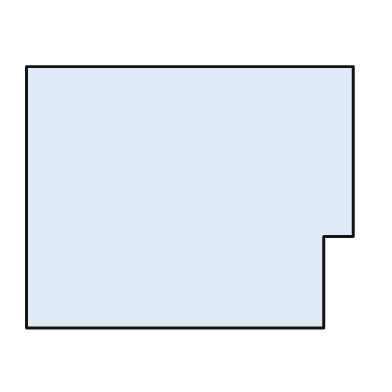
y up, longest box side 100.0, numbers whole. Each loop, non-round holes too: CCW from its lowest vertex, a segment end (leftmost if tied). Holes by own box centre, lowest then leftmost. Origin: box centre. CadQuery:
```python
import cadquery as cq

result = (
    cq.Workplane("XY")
    .moveTo(-50.0, -40.0)
    .lineTo(41.0, -40.0)
    .lineTo(41.0, -12.0)
    .lineTo(50.0, -12.0)
    .lineTo(50.0, 40.0)
    .lineTo(-50.0, 40.0)
    .close()
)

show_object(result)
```